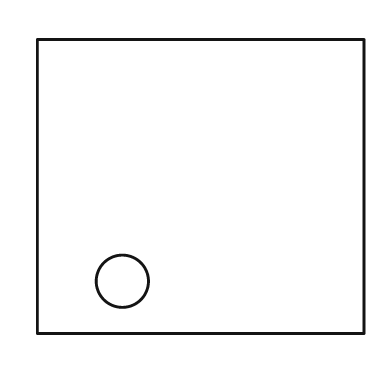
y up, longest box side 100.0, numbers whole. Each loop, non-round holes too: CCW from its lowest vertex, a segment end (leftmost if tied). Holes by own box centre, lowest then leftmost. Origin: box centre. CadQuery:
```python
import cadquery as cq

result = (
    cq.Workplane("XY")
    .moveTo(-50.0, -45.0)
    .lineTo(50.0, -45.0)
    .lineTo(50.0, 45.0)
    .lineTo(-50.0, 45.0)
    .close()
    .moveTo(-24.0, -29.0)
    .circle(8.0)
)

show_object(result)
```